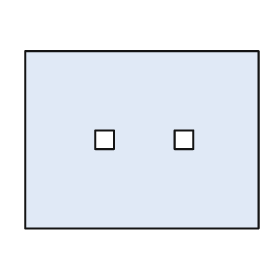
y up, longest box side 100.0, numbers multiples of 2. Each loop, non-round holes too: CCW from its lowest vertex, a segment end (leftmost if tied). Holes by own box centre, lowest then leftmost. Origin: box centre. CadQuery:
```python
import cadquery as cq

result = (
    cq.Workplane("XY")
    .moveTo(-50.0, -38.0)
    .lineTo(50.0, -38.0)
    .lineTo(50.0, 38.0)
    .lineTo(-50.0, 38.0)
    .close()
    .moveTo(-20.0, -4.0)
    .lineTo(-12.0, -4.0)
    .lineTo(-12.0, 4.0)
    .lineTo(-20.0, 4.0)
    .close()
    .moveTo(14.0, -4.0)
    .lineTo(22.0, -4.0)
    .lineTo(22.0, 4.0)
    .lineTo(14.0, 4.0)
    .close()
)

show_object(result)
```